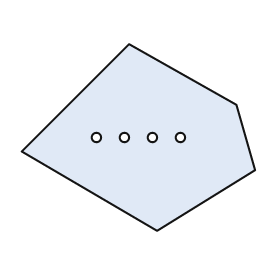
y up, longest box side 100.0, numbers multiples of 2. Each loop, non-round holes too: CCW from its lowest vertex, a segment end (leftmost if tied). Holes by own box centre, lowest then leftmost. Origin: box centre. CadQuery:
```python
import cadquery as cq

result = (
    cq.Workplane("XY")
    .moveTo(8.0, -40.0)
    .lineTo(50.0, -14.0)
    .lineTo(42.0, 14.0)
    .lineTo(-4.0, 40.0)
    .lineTo(-50.0, -6.0)
    .close()
    .moveTo(-18.0, 0.0)
    .circle(2.0)
    .moveTo(-6.0, 0.0)
    .circle(2.0)
    .moveTo(6.0, 0.0)
    .circle(2.0)
    .moveTo(18.0, 0.0)
    .circle(2.0)
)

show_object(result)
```